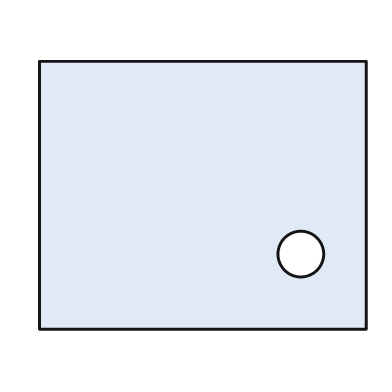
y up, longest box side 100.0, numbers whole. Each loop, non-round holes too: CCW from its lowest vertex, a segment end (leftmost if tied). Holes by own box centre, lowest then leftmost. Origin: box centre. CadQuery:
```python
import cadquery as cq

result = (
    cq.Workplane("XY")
    .moveTo(-50.0, -41.0)
    .lineTo(50.0, -41.0)
    .lineTo(50.0, 41.0)
    .lineTo(-50.0, 41.0)
    .close()
    .moveTo(30.0, -18.0)
    .circle(7.0)
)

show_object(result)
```